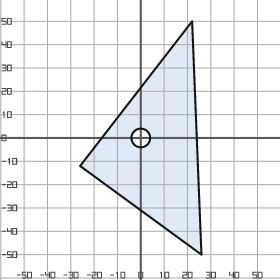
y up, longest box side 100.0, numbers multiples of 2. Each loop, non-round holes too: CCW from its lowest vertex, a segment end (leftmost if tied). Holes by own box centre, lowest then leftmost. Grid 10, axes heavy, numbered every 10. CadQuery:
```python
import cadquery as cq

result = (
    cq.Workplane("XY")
    .moveTo(26.0, -50.0)
    .lineTo(22.0, 50.0)
    .lineTo(-26.0, -12.0)
    .close()
    .moveTo(0.0, 0.0)
    .circle(4.0)
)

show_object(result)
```